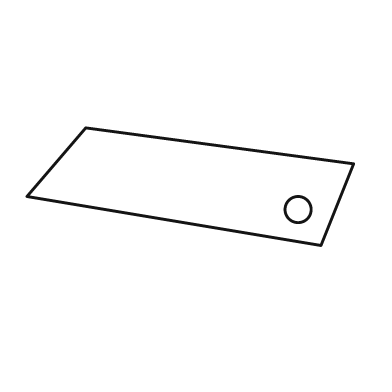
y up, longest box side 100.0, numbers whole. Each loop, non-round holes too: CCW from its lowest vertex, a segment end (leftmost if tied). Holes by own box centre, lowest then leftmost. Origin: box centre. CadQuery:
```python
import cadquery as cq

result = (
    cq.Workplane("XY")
    .moveTo(40.0, -18.0)
    .lineTo(50.0, 7.0)
    .lineTo(-32.0, 18.0)
    .lineTo(-50.0, -3.0)
    .close()
    .moveTo(33.0, -7.0)
    .circle(4.0)
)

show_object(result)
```